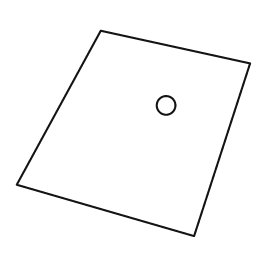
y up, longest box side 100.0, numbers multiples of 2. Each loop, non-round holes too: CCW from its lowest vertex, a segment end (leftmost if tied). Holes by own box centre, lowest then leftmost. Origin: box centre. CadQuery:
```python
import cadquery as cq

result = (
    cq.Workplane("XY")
    .moveTo(26.0, -44.0)
    .lineTo(50.0, 30.0)
    .lineTo(-14.0, 44.0)
    .lineTo(-50.0, -22.0)
    .close()
    .moveTo(14.0, 12.0)
    .circle(4.0)
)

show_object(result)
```